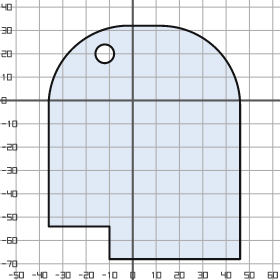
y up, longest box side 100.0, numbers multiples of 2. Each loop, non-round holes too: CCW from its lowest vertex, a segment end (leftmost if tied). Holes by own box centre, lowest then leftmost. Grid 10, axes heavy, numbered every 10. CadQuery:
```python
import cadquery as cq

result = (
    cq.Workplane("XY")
    .moveTo(-10.0, -68.0)
    .lineTo(46.0, -68.0)
    .lineTo(46.0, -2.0)
    .threePointArc((36.0, 22.0), (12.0, 32.0))
    .lineTo(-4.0, 32.0)
    .threePointArc((-26.0, 22.0), (-36.0, 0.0))
    .lineTo(-36.0, -54.0)
    .lineTo(-10.0, -54.0)
    .close()
    .moveTo(-12.0, 20.0)
    .circle(4.0)
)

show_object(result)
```